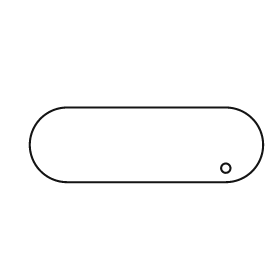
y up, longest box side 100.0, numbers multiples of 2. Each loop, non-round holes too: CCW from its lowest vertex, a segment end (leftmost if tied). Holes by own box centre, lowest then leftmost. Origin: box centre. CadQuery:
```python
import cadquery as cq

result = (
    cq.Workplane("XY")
    .moveTo(-34.0, -16.0)
    .lineTo(34.0, -16.0)
    .threePointArc((50.0, 0.0), (34.0, 16.0))
    .lineTo(-34.0, 16.0)
    .threePointArc((-50.0, 0.0), (-34.0, -16.0))
    .close()
    .moveTo(34.0, -10.0)
    .circle(2.0)
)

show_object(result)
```